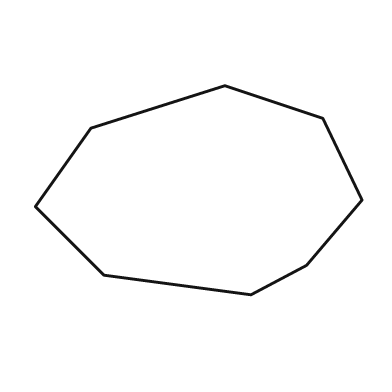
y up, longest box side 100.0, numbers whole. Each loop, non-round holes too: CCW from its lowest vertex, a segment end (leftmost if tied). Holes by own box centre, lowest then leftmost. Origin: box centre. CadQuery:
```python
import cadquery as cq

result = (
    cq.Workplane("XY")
    .moveTo(16.0, -32.0)
    .lineTo(33.0, -23.0)
    .lineTo(50.0, -3.0)
    .lineTo(38.0, 22.0)
    .lineTo(8.0, 32.0)
    .lineTo(-33.0, 19.0)
    .lineTo(-50.0, -5.0)
    .lineTo(-29.0, -26.0)
    .close()
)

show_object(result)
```